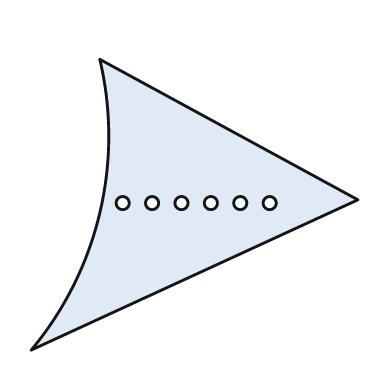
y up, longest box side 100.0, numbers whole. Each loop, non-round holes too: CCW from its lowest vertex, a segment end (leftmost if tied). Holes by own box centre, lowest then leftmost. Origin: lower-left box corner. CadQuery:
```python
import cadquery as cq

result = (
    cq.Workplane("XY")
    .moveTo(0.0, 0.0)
    .lineTo(100.0, 46.0)
    .lineTo(21.0, 89.0)
    .threePointArc((21.0, 42.0), (0.0, 0.0))
    .close()
    .moveTo(28.0, 45.0)
    .circle(2.0)
    .moveTo(37.0, 45.0)
    .circle(2.0)
    .moveTo(46.0, 45.0)
    .circle(2.0)
    .moveTo(55.0, 45.0)
    .circle(2.0)
    .moveTo(64.0, 45.0)
    .circle(2.0)
    .moveTo(73.0, 45.0)
    .circle(2.0)
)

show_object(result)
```